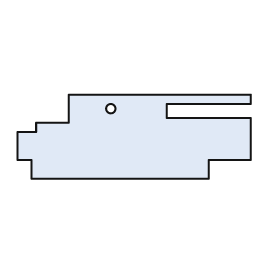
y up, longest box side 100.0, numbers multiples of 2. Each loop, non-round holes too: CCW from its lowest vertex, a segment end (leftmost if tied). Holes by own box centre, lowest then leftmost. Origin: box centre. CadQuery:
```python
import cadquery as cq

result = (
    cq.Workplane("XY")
    .moveTo(-44.0, -18.0)
    .lineTo(32.0, -18.0)
    .lineTo(32.0, -10.0)
    .lineTo(50.0, -10.0)
    .lineTo(50.0, 8.0)
    .lineTo(14.0, 8.0)
    .lineTo(14.0, 14.0)
    .lineTo(50.0, 14.0)
    .lineTo(50.0, 18.0)
    .lineTo(-28.0, 18.0)
    .lineTo(-28.0, 6.0)
    .lineTo(-42.0, 6.0)
    .lineTo(-42.0, 2.0)
    .lineTo(-50.0, 2.0)
    .lineTo(-50.0, -10.0)
    .lineTo(-44.0, -10.0)
    .close()
    .moveTo(-10.0, 12.0)
    .circle(2.0)
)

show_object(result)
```